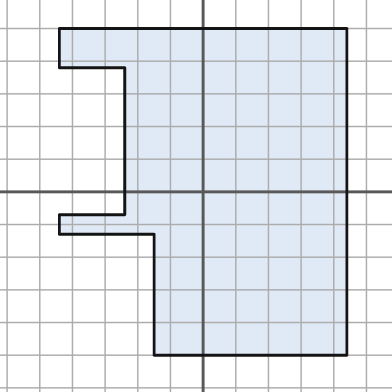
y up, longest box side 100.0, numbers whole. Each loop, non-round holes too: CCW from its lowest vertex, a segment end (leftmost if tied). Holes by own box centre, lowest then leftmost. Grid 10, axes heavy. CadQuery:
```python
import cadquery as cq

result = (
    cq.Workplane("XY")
    .moveTo(-15.0, -50.0)
    .lineTo(44.0, -50.0)
    .lineTo(44.0, 50.0)
    .lineTo(-44.0, 50.0)
    .lineTo(-44.0, 38.0)
    .lineTo(-24.0, 38.0)
    .lineTo(-24.0, -7.0)
    .lineTo(-44.0, -7.0)
    .lineTo(-44.0, -13.0)
    .lineTo(-15.0, -13.0)
    .close()
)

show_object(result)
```